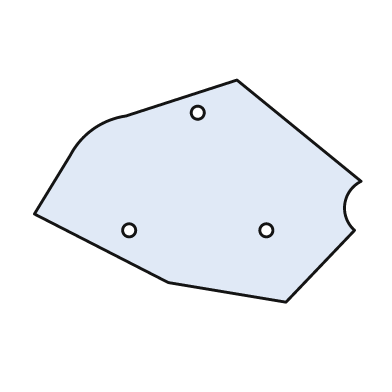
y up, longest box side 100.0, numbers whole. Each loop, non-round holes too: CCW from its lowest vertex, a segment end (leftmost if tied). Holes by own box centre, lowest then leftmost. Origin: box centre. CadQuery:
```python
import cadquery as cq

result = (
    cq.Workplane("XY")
    .moveTo(27.0, -34.0)
    .lineTo(48.0, -12.0)
    .threePointArc((45.0, -4.0), (50.0, 3.0))
    .lineTo(12.0, 34.0)
    .lineTo(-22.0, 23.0)
    .threePointArc((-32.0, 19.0), (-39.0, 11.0))
    .lineTo(-50.0, -7.0)
    .lineTo(-9.0, -28.0)
    .close()
    .moveTo(-21.0, -12.0)
    .circle(2.0)
    .moveTo(21.0, -12.0)
    .circle(2.0)
    .moveTo(0.0, 24.0)
    .circle(2.0)
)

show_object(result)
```